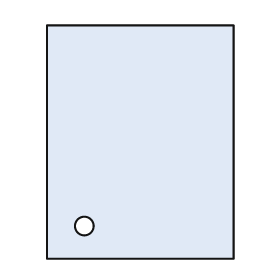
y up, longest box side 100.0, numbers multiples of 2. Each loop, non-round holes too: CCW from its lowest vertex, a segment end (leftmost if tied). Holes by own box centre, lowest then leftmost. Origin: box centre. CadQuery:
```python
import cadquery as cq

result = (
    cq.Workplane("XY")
    .moveTo(-40.0, -50.0)
    .lineTo(40.0, -50.0)
    .lineTo(40.0, 50.0)
    .lineTo(-40.0, 50.0)
    .close()
    .moveTo(-24.0, -36.0)
    .circle(4.0)
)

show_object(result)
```